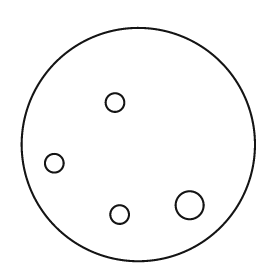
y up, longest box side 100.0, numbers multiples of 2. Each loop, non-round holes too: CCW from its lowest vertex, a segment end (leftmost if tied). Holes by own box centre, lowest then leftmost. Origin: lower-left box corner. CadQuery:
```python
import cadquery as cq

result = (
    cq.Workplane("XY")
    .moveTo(50.0, 50.0)
    .circle(50.0)
    .moveTo(42.0, 20.0)
    .circle(4.0)
    .moveTo(72.0, 24.0)
    .circle(6.0)
    .moveTo(14.0, 42.0)
    .circle(4.0)
    .moveTo(40.0, 68.0)
    .circle(4.0)
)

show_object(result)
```